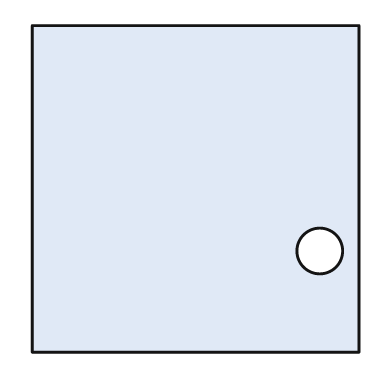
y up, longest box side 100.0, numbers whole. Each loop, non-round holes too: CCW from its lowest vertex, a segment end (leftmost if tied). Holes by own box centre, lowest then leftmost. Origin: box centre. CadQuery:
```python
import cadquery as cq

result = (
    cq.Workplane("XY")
    .moveTo(-50.0, -50.0)
    .lineTo(50.0, -50.0)
    .lineTo(50.0, 50.0)
    .lineTo(-50.0, 50.0)
    .close()
    .moveTo(38.0, -19.0)
    .circle(7.0)
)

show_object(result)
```